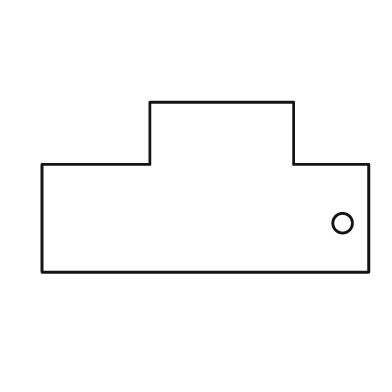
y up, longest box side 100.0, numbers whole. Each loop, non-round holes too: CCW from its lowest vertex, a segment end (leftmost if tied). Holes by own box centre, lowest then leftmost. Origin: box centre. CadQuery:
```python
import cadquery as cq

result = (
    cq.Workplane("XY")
    .moveTo(-50.0, -26.0)
    .lineTo(50.0, -26.0)
    .lineTo(50.0, 7.0)
    .lineTo(27.0, 7.0)
    .lineTo(27.0, 26.0)
    .lineTo(-17.0, 26.0)
    .lineTo(-17.0, 7.0)
    .lineTo(-50.0, 7.0)
    .close()
    .moveTo(42.0, -11.0)
    .circle(3.0)
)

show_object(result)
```